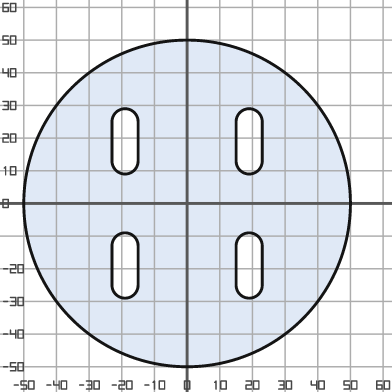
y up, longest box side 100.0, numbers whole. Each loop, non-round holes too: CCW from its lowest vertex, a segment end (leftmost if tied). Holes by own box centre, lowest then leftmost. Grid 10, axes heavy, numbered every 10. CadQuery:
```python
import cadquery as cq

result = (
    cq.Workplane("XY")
    .moveTo(0.0, 0.0)
    .circle(50.0)
    .moveTo(-23.0, -25.0)
    .threePointArc((-19.0, -29.0), (-15.0, -25.0))
    .lineTo(-15.0, -13.0)
    .threePointArc((-19.0, -9.0), (-23.0, -13.0))
    .close()
    .moveTo(15.0, -25.0)
    .threePointArc((19.0, -29.0), (23.0, -25.0))
    .lineTo(23.0, -13.0)
    .threePointArc((19.0, -9.0), (15.0, -13.0))
    .close()
    .moveTo(-23.0, 13.0)
    .threePointArc((-19.0, 9.0), (-15.0, 13.0))
    .lineTo(-15.0, 25.0)
    .threePointArc((-19.0, 29.0), (-23.0, 25.0))
    .close()
    .moveTo(15.0, 13.0)
    .threePointArc((19.0, 9.0), (23.0, 13.0))
    .lineTo(23.0, 25.0)
    .threePointArc((19.0, 29.0), (15.0, 25.0))
    .close()
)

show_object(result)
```